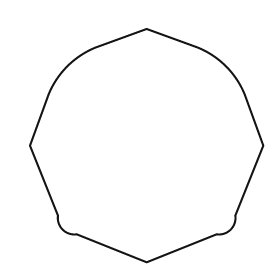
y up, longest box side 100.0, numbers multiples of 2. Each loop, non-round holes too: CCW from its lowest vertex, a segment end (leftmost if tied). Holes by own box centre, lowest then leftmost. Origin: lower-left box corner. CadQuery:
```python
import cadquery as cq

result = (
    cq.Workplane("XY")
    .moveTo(50.0, 0.0)
    .lineTo(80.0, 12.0)
    .threePointArc((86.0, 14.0), (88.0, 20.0))
    .lineTo(100.0, 50.0)
    .lineTo(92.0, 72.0)
    .threePointArc((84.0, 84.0), (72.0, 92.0))
    .lineTo(50.0, 100.0)
    .lineTo(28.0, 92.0)
    .threePointArc((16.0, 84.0), (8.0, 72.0))
    .lineTo(0.0, 50.0)
    .lineTo(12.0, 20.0)
    .threePointArc((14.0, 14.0), (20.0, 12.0))
    .close()
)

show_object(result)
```